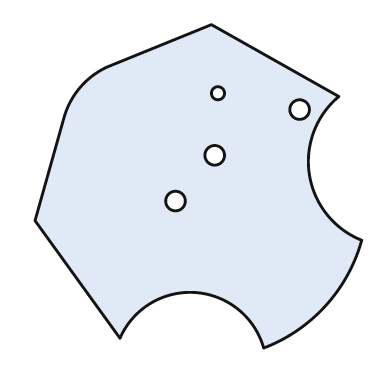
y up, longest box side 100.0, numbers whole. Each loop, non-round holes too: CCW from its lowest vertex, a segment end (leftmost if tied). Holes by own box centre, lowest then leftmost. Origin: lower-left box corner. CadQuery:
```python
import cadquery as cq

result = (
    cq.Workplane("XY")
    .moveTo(70.0, 0.0)
    .threePointArc((89.0, 13.0), (100.0, 33.0))
    .threePointArc((84.0, 53.0), (93.0, 77.0))
    .lineTo(54.0, 99.0)
    .lineTo(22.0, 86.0)
    .threePointArc((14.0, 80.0), (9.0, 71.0))
    .lineTo(0.0, 39.0)
    .lineTo(26.0, 3.0)
    .threePointArc((49.0, 17.0), (70.0, 0.0))
    .close()
    .moveTo(43.0, 45.0)
    .circle(3.0)
    .moveTo(55.0, 59.0)
    .circle(3.0)
    .moveTo(81.0, 73.0)
    .circle(3.0)
    .moveTo(56.0, 78.0)
    .circle(2.0)
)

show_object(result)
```